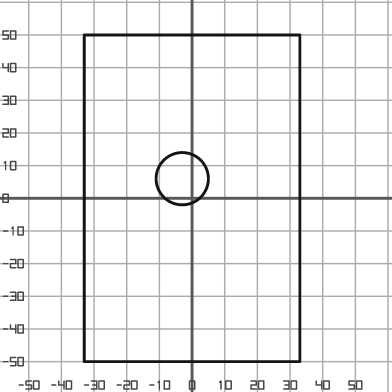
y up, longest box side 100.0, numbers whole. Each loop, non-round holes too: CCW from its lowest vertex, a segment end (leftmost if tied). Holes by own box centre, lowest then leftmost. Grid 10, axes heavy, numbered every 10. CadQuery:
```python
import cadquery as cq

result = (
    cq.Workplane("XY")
    .moveTo(-33.0, -50.0)
    .lineTo(33.0, -50.0)
    .lineTo(33.0, 50.0)
    .lineTo(-33.0, 50.0)
    .close()
    .moveTo(-3.0, 6.0)
    .circle(8.0)
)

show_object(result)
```